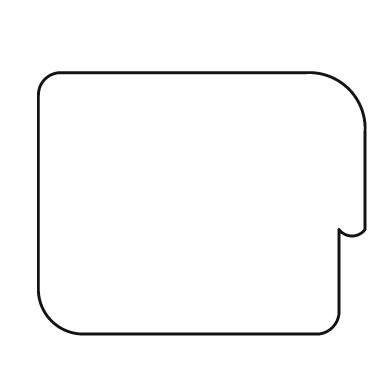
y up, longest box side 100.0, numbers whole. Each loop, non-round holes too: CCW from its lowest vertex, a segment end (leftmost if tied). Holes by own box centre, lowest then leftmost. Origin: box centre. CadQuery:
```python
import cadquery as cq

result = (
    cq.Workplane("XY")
    .moveTo(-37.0, -40.0)
    .lineTo(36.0, -40.0)
    .threePointArc((40.0, -38.0), (42.0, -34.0))
    .lineTo(42.0, -8.0)
    .threePointArc((46.0, -10.0), (50.0, -8.0))
    .lineTo(50.0, 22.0)
    .threePointArc((45.0, 35.0), (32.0, 40.0))
    .lineTo(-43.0, 40.0)
    .threePointArc((-48.0, 38.0), (-50.0, 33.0))
    .lineTo(-50.0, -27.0)
    .threePointArc((-46.0, -36.0), (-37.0, -40.0))
    .close()
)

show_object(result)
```